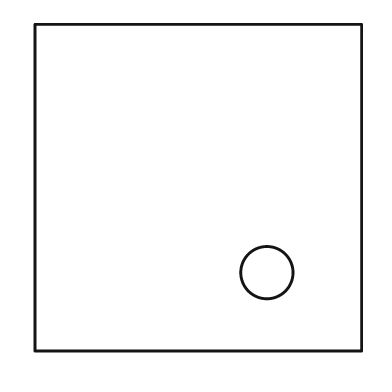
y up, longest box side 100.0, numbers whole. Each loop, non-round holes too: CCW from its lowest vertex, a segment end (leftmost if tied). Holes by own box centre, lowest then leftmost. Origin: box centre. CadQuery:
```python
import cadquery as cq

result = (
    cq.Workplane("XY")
    .moveTo(-50.0, -50.0)
    .lineTo(50.0, -50.0)
    .lineTo(50.0, 50.0)
    .lineTo(-50.0, 50.0)
    .close()
    .moveTo(21.0, -26.0)
    .circle(8.0)
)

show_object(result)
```